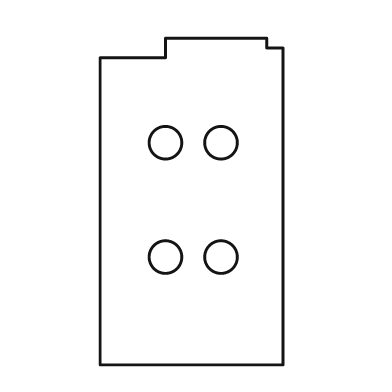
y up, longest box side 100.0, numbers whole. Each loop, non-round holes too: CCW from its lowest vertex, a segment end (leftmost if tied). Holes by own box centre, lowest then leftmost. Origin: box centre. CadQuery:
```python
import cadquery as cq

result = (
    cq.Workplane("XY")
    .moveTo(-28.0, -50.0)
    .lineTo(28.0, -50.0)
    .lineTo(28.0, 47.0)
    .lineTo(23.0, 47.0)
    .lineTo(23.0, 50.0)
    .lineTo(-8.0, 50.0)
    .lineTo(-8.0, 44.0)
    .lineTo(-28.0, 44.0)
    .close()
    .moveTo(-8.0, -17.0)
    .circle(5.0)
    .moveTo(9.0, -17.0)
    .circle(5.0)
    .moveTo(-8.0, 18.0)
    .circle(5.0)
    .moveTo(9.0, 18.0)
    .circle(5.0)
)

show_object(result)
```